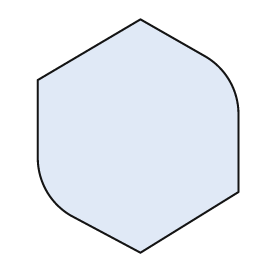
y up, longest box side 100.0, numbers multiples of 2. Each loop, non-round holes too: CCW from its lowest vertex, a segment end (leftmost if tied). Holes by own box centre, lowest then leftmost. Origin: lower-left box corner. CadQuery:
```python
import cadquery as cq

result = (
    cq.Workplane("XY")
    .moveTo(44.0, 0.0)
    .lineTo(86.0, 26.0)
    .lineTo(86.0, 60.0)
    .threePointArc((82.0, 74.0), (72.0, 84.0))
    .lineTo(44.0, 100.0)
    .lineTo(0.0, 74.0)
    .lineTo(0.0, 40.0)
    .threePointArc((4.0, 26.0), (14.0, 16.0))
    .close()
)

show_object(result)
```